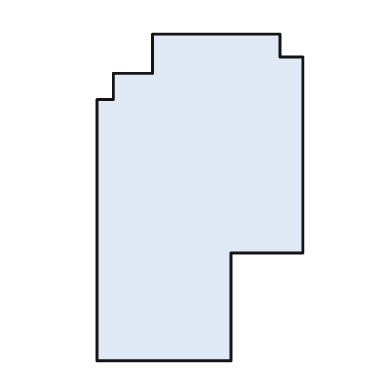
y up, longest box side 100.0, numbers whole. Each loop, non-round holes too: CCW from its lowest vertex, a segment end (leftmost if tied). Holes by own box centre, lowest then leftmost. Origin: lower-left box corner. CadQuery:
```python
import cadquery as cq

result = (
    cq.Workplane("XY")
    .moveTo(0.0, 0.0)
    .lineTo(41.0, 0.0)
    .lineTo(41.0, 33.0)
    .lineTo(63.0, 33.0)
    .lineTo(63.0, 93.0)
    .lineTo(56.0, 93.0)
    .lineTo(56.0, 100.0)
    .lineTo(17.0, 100.0)
    .lineTo(17.0, 88.0)
    .lineTo(5.0, 88.0)
    .lineTo(5.0, 80.0)
    .lineTo(0.0, 80.0)
    .close()
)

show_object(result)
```